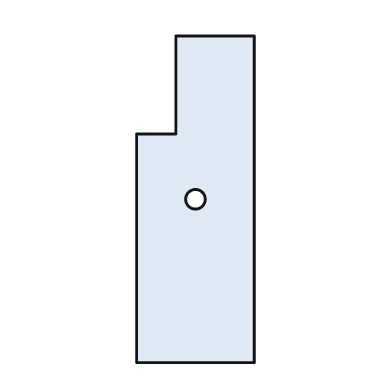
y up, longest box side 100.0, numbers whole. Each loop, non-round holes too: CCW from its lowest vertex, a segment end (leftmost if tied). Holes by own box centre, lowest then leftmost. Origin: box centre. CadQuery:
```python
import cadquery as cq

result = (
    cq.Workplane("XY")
    .moveTo(-18.0, -50.0)
    .lineTo(18.0, -50.0)
    .lineTo(18.0, 50.0)
    .lineTo(-6.0, 50.0)
    .lineTo(-6.0, 20.0)
    .lineTo(-18.0, 20.0)
    .close()
    .moveTo(0.0, 0.0)
    .circle(3.0)
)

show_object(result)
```